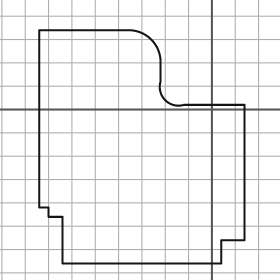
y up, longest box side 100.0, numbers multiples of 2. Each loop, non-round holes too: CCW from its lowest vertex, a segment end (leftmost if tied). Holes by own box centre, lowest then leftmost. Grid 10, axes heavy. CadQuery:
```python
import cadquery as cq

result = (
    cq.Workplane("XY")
    .moveTo(-64.0, -66.0)
    .lineTo(4.0, -66.0)
    .lineTo(4.0, -56.0)
    .lineTo(14.0, -56.0)
    .lineTo(14.0, 2.0)
    .lineTo(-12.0, 2.0)
    .threePointArc((-20.0, 4.0), (-22.0, 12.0))
    .lineTo(-22.0, 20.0)
    .threePointArc((-26.0, 30.0), (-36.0, 34.0))
    .lineTo(-74.0, 34.0)
    .lineTo(-74.0, -42.0)
    .lineTo(-70.0, -42.0)
    .lineTo(-70.0, -46.0)
    .lineTo(-64.0, -46.0)
    .close()
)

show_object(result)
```